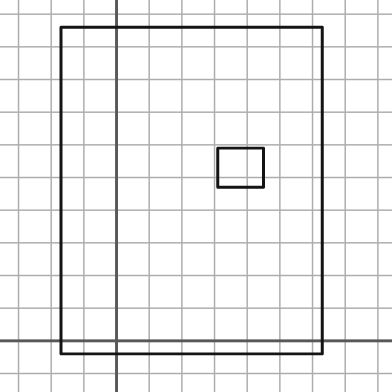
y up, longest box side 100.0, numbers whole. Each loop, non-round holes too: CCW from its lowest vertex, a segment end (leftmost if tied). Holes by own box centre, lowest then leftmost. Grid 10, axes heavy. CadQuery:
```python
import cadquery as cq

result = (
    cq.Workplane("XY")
    .moveTo(-17.0, -4.0)
    .lineTo(63.0, -4.0)
    .lineTo(63.0, 96.0)
    .lineTo(-17.0, 96.0)
    .close()
    .moveTo(31.0, 47.0)
    .lineTo(45.0, 47.0)
    .lineTo(45.0, 59.0)
    .lineTo(31.0, 59.0)
    .close()
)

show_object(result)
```